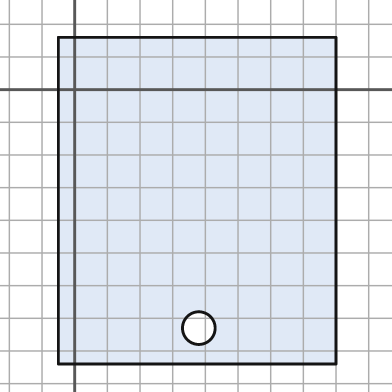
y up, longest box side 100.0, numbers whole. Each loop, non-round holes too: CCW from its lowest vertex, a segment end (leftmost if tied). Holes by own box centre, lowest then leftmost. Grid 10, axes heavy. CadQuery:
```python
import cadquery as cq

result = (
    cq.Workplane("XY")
    .moveTo(-5.0, -84.0)
    .lineTo(80.0, -84.0)
    .lineTo(80.0, 16.0)
    .lineTo(-5.0, 16.0)
    .close()
    .moveTo(38.0, -73.0)
    .circle(5.0)
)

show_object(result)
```